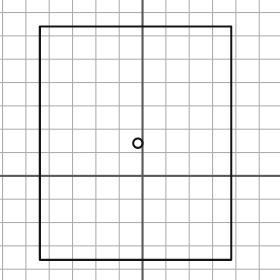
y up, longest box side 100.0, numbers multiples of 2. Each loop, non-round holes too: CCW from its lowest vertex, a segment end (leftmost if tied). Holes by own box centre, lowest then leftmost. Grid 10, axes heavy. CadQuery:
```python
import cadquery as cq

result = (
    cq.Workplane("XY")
    .moveTo(-44.0, -36.0)
    .lineTo(38.0, -36.0)
    .lineTo(38.0, 64.0)
    .lineTo(-44.0, 64.0)
    .close()
    .moveTo(-2.0, 14.0)
    .circle(2.0)
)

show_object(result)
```